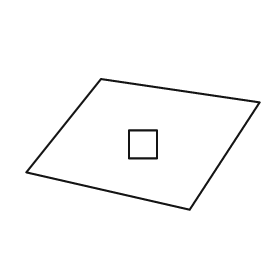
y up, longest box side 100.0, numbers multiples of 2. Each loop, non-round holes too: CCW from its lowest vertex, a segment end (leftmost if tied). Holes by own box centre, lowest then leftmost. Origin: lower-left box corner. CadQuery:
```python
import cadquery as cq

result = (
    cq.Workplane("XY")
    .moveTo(70.0, 0.0)
    .lineTo(100.0, 46.0)
    .lineTo(32.0, 56.0)
    .lineTo(0.0, 16.0)
    .close()
    .moveTo(44.0, 22.0)
    .lineTo(56.0, 22.0)
    .lineTo(56.0, 34.0)
    .lineTo(44.0, 34.0)
    .close()
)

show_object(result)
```